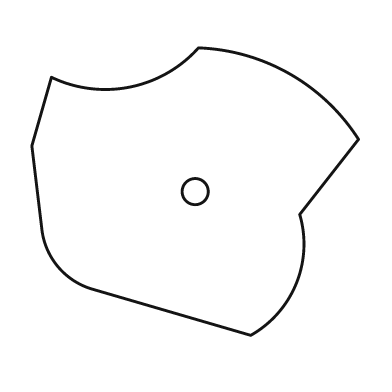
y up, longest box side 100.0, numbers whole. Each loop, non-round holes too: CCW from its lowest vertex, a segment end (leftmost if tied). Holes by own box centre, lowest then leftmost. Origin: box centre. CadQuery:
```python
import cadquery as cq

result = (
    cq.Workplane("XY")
    .moveTo(17.0, -44.0)
    .threePointArc((31.0, -28.0), (32.0, -7.0))
    .lineTo(50.0, 16.0)
    .threePointArc((29.0, 36.0), (1.0, 44.0))
    .threePointArc((-20.0, 32.0), (-44.0, 35.0))
    .lineTo(-50.0, 14.0)
    .lineTo(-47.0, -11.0)
    .threePointArc((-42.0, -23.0), (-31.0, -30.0))
    .close()
    .moveTo(0.0, 0.0)
    .circle(4.0)
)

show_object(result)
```